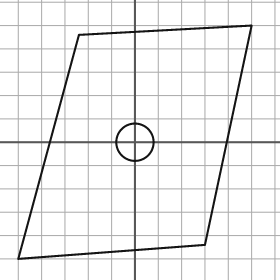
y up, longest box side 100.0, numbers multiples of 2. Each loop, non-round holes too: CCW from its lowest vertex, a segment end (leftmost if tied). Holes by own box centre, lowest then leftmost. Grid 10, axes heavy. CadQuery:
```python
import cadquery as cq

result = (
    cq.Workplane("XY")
    .moveTo(-50.0, -50.0)
    .lineTo(30.0, -44.0)
    .lineTo(50.0, 50.0)
    .lineTo(-24.0, 46.0)
    .close()
    .moveTo(0.0, 0.0)
    .circle(8.0)
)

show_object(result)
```